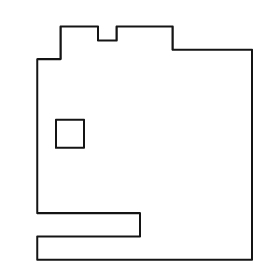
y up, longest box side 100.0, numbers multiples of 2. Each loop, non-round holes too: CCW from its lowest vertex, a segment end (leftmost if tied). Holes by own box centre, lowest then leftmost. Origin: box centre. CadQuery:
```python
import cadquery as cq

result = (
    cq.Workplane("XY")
    .moveTo(-46.0, -50.0)
    .lineTo(46.0, -50.0)
    .lineTo(46.0, 40.0)
    .lineTo(12.0, 40.0)
    .lineTo(12.0, 50.0)
    .lineTo(-12.0, 50.0)
    .lineTo(-12.0, 44.0)
    .lineTo(-20.0, 44.0)
    .lineTo(-20.0, 50.0)
    .lineTo(-36.0, 50.0)
    .lineTo(-36.0, 36.0)
    .lineTo(-46.0, 36.0)
    .lineTo(-46.0, -30.0)
    .lineTo(-2.0, -30.0)
    .lineTo(-2.0, -40.0)
    .lineTo(-46.0, -40.0)
    .close()
    .moveTo(-38.0, -2.0)
    .lineTo(-26.0, -2.0)
    .lineTo(-26.0, 10.0)
    .lineTo(-38.0, 10.0)
    .close()
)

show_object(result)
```